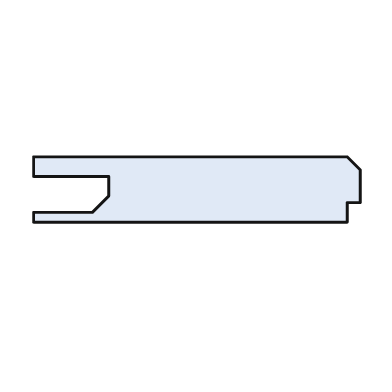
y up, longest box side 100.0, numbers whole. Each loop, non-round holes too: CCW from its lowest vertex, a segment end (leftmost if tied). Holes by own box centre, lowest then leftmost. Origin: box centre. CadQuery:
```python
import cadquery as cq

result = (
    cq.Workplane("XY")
    .moveTo(-50.0, -10.0)
    .lineTo(46.0, -10.0)
    .lineTo(46.0, -4.0)
    .lineTo(50.0, -4.0)
    .lineTo(50.0, 6.0)
    .lineTo(46.0, 10.0)
    .lineTo(-50.0, 10.0)
    .lineTo(-50.0, 4.0)
    .lineTo(-27.0, 4.0)
    .lineTo(-27.0, -2.0)
    .lineTo(-32.0, -7.0)
    .lineTo(-50.0, -7.0)
    .close()
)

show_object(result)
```